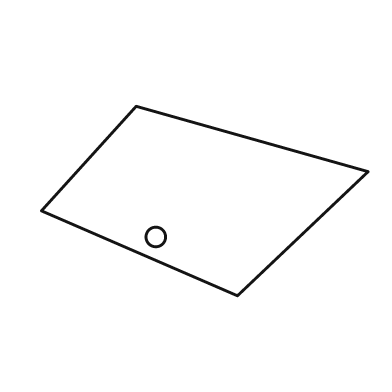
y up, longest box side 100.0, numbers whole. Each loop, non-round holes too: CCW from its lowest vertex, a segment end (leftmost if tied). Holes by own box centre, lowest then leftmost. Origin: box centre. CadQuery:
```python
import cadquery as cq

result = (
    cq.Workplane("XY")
    .moveTo(10.0, -29.0)
    .lineTo(50.0, 9.0)
    .lineTo(-21.0, 29.0)
    .lineTo(-50.0, -3.0)
    .close()
    .moveTo(-15.0, -11.0)
    .circle(3.0)
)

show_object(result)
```